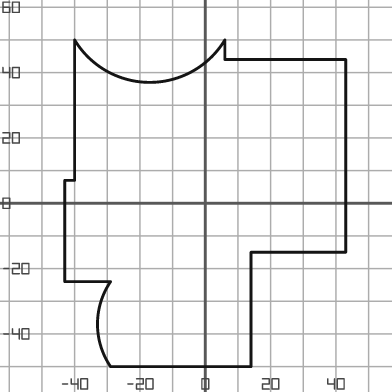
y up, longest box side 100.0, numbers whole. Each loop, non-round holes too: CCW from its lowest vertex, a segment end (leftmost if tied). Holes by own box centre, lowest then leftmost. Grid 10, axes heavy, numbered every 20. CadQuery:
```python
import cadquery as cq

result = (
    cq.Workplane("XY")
    .moveTo(-29.0, -50.0)
    .lineTo(14.0, -50.0)
    .lineTo(14.0, -15.0)
    .lineTo(43.0, -15.0)
    .lineTo(43.0, 44.0)
    .lineTo(6.0, 44.0)
    .lineTo(6.0, 50.0)
    .threePointArc((-17.0, 37.0), (-40.0, 50.0))
    .lineTo(-40.0, 7.0)
    .lineTo(-43.0, 7.0)
    .lineTo(-43.0, -24.0)
    .lineTo(-29.0, -24.0)
    .threePointArc((-33.0, -37.0), (-29.0, -50.0))
    .close()
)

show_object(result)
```